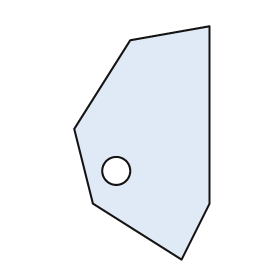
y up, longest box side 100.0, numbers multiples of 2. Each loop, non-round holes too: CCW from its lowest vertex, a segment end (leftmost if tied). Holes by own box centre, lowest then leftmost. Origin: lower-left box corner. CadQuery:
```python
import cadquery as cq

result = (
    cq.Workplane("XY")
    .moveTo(46.0, 0.0)
    .lineTo(58.0, 24.0)
    .lineTo(58.0, 100.0)
    .lineTo(24.0, 94.0)
    .lineTo(0.0, 56.0)
    .lineTo(8.0, 24.0)
    .close()
    .moveTo(18.0, 38.0)
    .circle(6.0)
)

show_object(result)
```